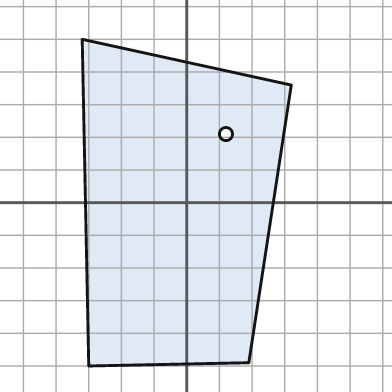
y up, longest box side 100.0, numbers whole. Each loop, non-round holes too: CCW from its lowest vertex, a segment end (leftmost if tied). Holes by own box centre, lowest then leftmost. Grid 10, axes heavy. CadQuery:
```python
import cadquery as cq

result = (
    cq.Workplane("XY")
    .moveTo(-30.0, -50.0)
    .lineTo(19.0, -49.0)
    .lineTo(32.0, 36.0)
    .lineTo(-32.0, 50.0)
    .close()
    .moveTo(12.0, 21.0)
    .circle(2.0)
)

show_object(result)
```